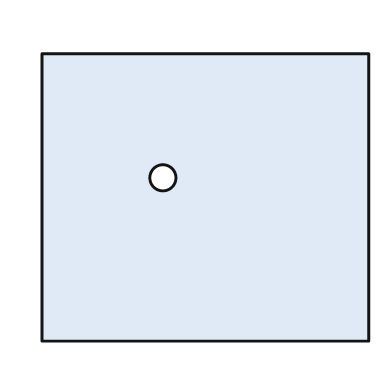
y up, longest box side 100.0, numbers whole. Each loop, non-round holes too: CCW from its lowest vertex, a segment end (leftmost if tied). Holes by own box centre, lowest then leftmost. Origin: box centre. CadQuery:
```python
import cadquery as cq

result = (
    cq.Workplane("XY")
    .moveTo(-50.0, -44.0)
    .lineTo(50.0, -44.0)
    .lineTo(50.0, 44.0)
    .lineTo(-50.0, 44.0)
    .close()
    .moveTo(-13.0, 6.0)
    .circle(4.0)
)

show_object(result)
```